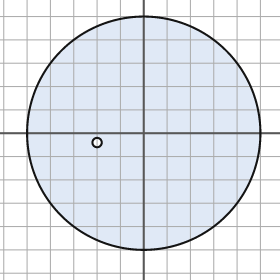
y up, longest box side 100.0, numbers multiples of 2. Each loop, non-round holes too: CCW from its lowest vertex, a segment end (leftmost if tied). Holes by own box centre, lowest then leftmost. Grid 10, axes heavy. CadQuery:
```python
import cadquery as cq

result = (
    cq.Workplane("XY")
    .moveTo(0.0, 0.0)
    .circle(50.0)
    .moveTo(-20.0, -4.0)
    .circle(2.0)
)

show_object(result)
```